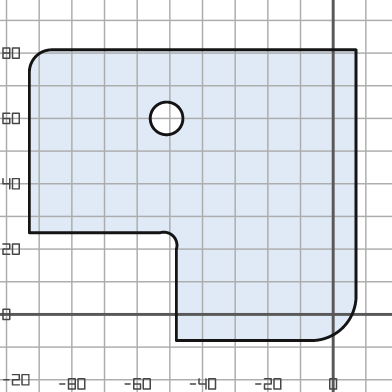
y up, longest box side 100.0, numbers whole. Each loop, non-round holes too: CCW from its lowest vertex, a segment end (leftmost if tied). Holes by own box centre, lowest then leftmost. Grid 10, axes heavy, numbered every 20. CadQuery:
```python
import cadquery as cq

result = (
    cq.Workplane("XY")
    .moveTo(-48.0, -8.0)
    .lineTo(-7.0, -8.0)
    .threePointArc((3.0, -4.0), (7.0, 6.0))
    .lineTo(7.0, 81.0)
    .lineTo(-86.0, 81.0)
    .threePointArc((-91.0, 79.0), (-93.0, 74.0))
    .lineTo(-93.0, 25.0)
    .lineTo(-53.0, 25.0)
    .threePointArc((-49.0, 24.0), (-48.0, 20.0))
    .close()
    .moveTo(-51.0, 60.0)
    .circle(5.0)
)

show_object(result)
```